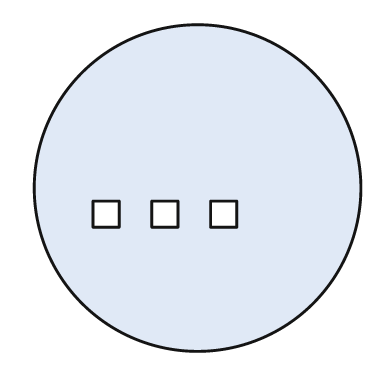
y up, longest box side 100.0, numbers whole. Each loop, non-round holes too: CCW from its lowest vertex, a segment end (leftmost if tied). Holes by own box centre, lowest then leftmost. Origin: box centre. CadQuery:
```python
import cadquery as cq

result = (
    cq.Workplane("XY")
    .moveTo(0.0, 0.0)
    .circle(50.0)
    .moveTo(-32.0, -12.0)
    .lineTo(-24.0, -12.0)
    .lineTo(-24.0, -4.0)
    .lineTo(-32.0, -4.0)
    .close()
    .moveTo(-14.0, -12.0)
    .lineTo(-6.0, -12.0)
    .lineTo(-6.0, -4.0)
    .lineTo(-14.0, -4.0)
    .close()
    .moveTo(4.0, -12.0)
    .lineTo(12.0, -12.0)
    .lineTo(12.0, -4.0)
    .lineTo(4.0, -4.0)
    .close()
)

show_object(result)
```